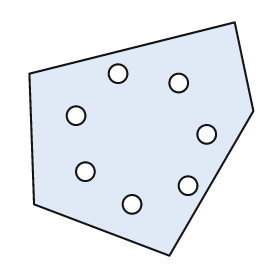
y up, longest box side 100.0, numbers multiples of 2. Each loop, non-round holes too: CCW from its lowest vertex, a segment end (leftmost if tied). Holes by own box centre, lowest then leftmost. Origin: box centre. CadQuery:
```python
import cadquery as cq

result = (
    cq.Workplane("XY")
    .moveTo(12.0, -50.0)
    .lineTo(48.0, 12.0)
    .lineTo(40.0, 50.0)
    .lineTo(-48.0, 28.0)
    .lineTo(-46.0, -28.0)
    .close()
    .moveTo(-4.0, -28.0)
    .circle(4.0)
    .moveTo(20.0, -20.0)
    .circle(4.0)
    .moveTo(-24.0, -14.0)
    .circle(4.0)
    .moveTo(28.0, 2.0)
    .circle(4.0)
    .moveTo(-28.0, 10.0)
    .circle(4.0)
    .moveTo(16.0, 24.0)
    .circle(4.0)
    .moveTo(-10.0, 28.0)
    .circle(4.0)
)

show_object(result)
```